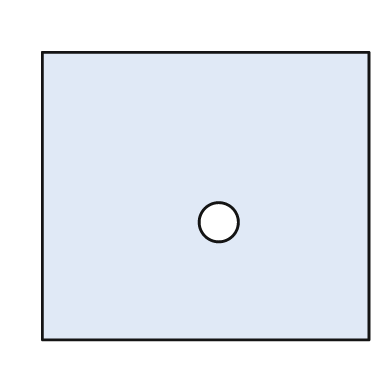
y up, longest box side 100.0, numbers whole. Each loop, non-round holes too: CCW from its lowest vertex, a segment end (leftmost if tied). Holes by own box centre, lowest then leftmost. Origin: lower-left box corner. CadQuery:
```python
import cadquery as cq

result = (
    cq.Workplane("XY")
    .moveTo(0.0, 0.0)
    .lineTo(100.0, 0.0)
    .lineTo(100.0, 88.0)
    .lineTo(0.0, 88.0)
    .close()
    .moveTo(54.0, 36.0)
    .circle(6.0)
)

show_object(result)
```